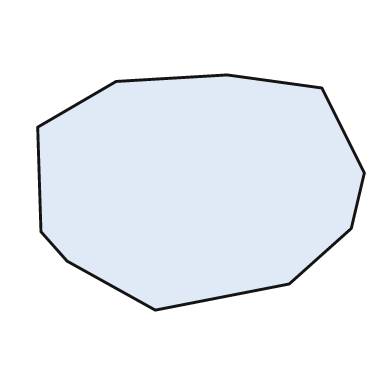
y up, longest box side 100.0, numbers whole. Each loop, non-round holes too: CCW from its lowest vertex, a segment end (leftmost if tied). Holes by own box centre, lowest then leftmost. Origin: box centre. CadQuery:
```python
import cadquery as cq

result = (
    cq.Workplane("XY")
    .moveTo(-14.0, -36.0)
    .lineTo(27.0, -28.0)
    .lineTo(46.0, -11.0)
    .lineTo(50.0, 6.0)
    .lineTo(37.0, 32.0)
    .lineTo(8.0, 36.0)
    .lineTo(-26.0, 34.0)
    .lineTo(-50.0, 20.0)
    .lineTo(-49.0, -12.0)
    .lineTo(-41.0, -21.0)
    .close()
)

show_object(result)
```